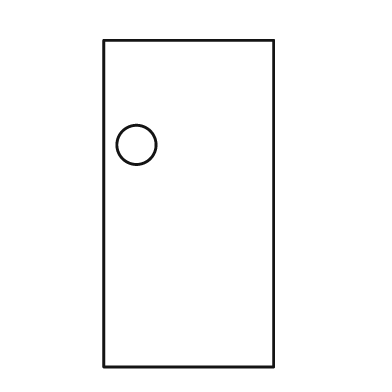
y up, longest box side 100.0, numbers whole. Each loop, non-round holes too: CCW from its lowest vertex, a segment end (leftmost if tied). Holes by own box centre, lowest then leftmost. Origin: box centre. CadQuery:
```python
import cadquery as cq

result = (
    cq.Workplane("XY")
    .moveTo(-26.0, -50.0)
    .lineTo(26.0, -50.0)
    .lineTo(26.0, 50.0)
    .lineTo(-26.0, 50.0)
    .close()
    .moveTo(-16.0, 18.0)
    .circle(6.0)
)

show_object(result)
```